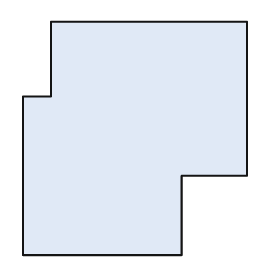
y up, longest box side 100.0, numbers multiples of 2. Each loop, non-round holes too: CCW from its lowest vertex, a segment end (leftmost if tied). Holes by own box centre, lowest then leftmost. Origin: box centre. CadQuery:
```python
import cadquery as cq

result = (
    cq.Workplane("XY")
    .moveTo(-48.0, -50.0)
    .lineTo(20.0, -50.0)
    .lineTo(20.0, -16.0)
    .lineTo(48.0, -16.0)
    .lineTo(48.0, 50.0)
    .lineTo(-36.0, 50.0)
    .lineTo(-36.0, 18.0)
    .lineTo(-48.0, 18.0)
    .close()
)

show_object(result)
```